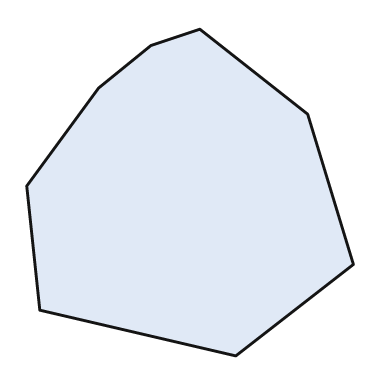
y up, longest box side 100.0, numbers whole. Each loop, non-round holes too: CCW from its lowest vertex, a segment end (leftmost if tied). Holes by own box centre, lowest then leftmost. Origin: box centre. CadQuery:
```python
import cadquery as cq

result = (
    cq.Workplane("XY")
    .moveTo(14.0, -50.0)
    .lineTo(50.0, -22.0)
    .lineTo(36.0, 24.0)
    .lineTo(3.0, 50.0)
    .lineTo(-12.0, 45.0)
    .lineTo(-28.0, 32.0)
    .lineTo(-50.0, 2.0)
    .lineTo(-46.0, -36.0)
    .close()
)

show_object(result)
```